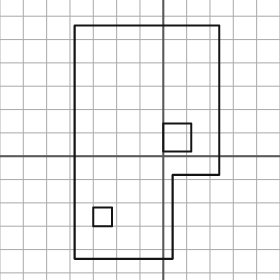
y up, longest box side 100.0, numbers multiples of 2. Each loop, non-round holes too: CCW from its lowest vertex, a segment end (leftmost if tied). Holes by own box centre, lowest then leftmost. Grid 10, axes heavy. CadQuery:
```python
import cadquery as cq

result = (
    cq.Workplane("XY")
    .moveTo(-38.0, -44.0)
    .lineTo(4.0, -44.0)
    .lineTo(4.0, -8.0)
    .lineTo(24.0, -8.0)
    .lineTo(24.0, 56.0)
    .lineTo(-38.0, 56.0)
    .close()
    .moveTo(-30.0, -30.0)
    .lineTo(-22.0, -30.0)
    .lineTo(-22.0, -22.0)
    .lineTo(-30.0, -22.0)
    .close()
    .moveTo(0.0, 2.0)
    .lineTo(12.0, 2.0)
    .lineTo(12.0, 14.0)
    .lineTo(0.0, 14.0)
    .close()
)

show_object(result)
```